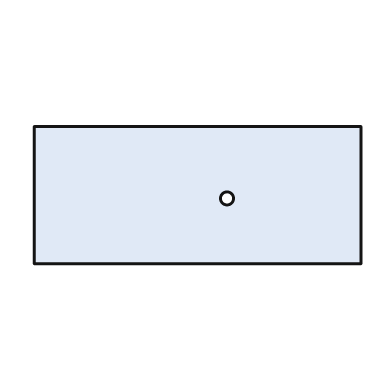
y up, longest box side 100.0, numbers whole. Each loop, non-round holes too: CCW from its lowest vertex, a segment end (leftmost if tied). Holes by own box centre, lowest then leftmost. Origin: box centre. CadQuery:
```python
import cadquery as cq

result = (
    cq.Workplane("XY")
    .moveTo(-50.0, -21.0)
    .lineTo(50.0, -21.0)
    .lineTo(50.0, 21.0)
    .lineTo(-50.0, 21.0)
    .close()
    .moveTo(9.0, -1.0)
    .circle(2.0)
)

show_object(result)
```